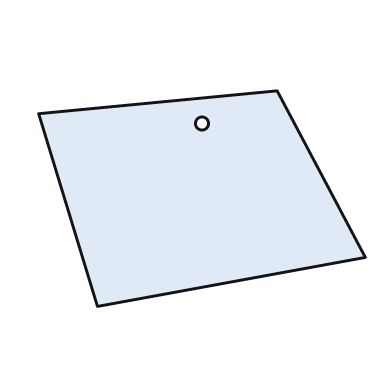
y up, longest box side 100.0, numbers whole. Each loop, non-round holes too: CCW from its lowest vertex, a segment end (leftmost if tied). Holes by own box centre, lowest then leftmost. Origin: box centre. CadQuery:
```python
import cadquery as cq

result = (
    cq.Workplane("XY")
    .moveTo(-32.0, -33.0)
    .lineTo(50.0, -18.0)
    .lineTo(23.0, 33.0)
    .lineTo(-50.0, 26.0)
    .close()
    .moveTo(0.0, 23.0)
    .circle(2.0)
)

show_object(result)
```